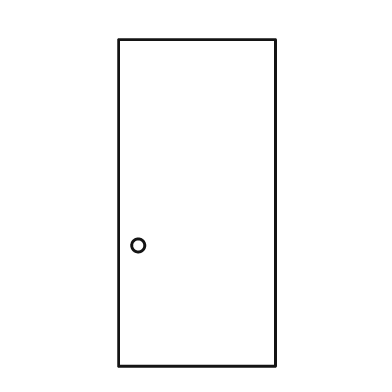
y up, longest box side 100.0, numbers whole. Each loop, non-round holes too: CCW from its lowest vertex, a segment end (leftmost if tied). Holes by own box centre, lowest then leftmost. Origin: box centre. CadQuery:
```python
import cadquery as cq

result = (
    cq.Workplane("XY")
    .moveTo(-24.0, -50.0)
    .lineTo(24.0, -50.0)
    .lineTo(24.0, 50.0)
    .lineTo(-24.0, 50.0)
    .close()
    .moveTo(-18.0, -13.0)
    .circle(2.0)
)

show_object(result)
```